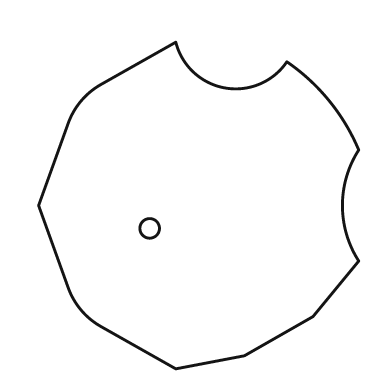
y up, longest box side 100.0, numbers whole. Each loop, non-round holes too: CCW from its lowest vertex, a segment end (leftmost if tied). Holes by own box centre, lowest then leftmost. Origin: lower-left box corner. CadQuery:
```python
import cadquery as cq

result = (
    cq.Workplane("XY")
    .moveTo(42.0, 0.0)
    .lineTo(63.0, 4.0)
    .lineTo(84.0, 16.0)
    .lineTo(98.0, 33.0)
    .threePointArc((93.0, 50.0), (98.0, 67.0))
    .threePointArc((89.0, 82.0), (76.0, 94.0))
    .threePointArc((57.0, 86.0), (42.0, 100.0))
    .lineTo(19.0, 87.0)
    .threePointArc((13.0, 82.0), (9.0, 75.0))
    .lineTo(0.0, 50.0)
    .lineTo(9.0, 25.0)
    .threePointArc((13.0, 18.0), (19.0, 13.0))
    .close()
    .moveTo(34.0, 43.0)
    .circle(3.0)
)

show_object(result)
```